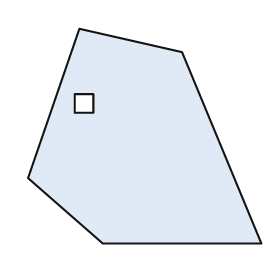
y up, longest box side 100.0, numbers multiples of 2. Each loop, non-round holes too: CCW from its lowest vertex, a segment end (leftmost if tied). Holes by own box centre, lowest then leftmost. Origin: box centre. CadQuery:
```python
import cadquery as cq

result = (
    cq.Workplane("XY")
    .moveTo(-18.0, -46.0)
    .lineTo(50.0, -46.0)
    .lineTo(16.0, 36.0)
    .lineTo(-28.0, 46.0)
    .lineTo(-50.0, -18.0)
    .close()
    .moveTo(-30.0, 10.0)
    .lineTo(-22.0, 10.0)
    .lineTo(-22.0, 18.0)
    .lineTo(-30.0, 18.0)
    .close()
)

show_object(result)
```